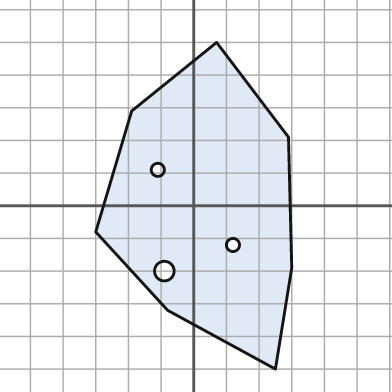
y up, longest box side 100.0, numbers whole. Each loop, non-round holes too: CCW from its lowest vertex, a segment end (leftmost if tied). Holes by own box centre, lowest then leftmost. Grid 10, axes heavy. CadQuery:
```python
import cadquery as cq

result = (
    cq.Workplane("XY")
    .moveTo(25.0, -50.0)
    .lineTo(30.0, -19.0)
    .lineTo(29.0, 21.0)
    .lineTo(7.0, 50.0)
    .lineTo(-19.0, 29.0)
    .lineTo(-30.0, -8.0)
    .lineTo(-8.0, -32.0)
    .close()
    .moveTo(-9.0, -20.0)
    .circle(3.0)
    .moveTo(12.0, -12.0)
    .circle(2.0)
    .moveTo(-11.0, 11.0)
    .circle(2.0)
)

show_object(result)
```